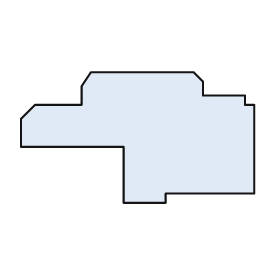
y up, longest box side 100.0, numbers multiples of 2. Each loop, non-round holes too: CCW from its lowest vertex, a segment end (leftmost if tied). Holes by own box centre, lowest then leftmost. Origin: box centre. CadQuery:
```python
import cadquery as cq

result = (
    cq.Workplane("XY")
    .moveTo(-6.0, -28.0)
    .lineTo(12.0, -28.0)
    .lineTo(12.0, -24.0)
    .lineTo(50.0, -24.0)
    .lineTo(50.0, 14.0)
    .lineTo(46.0, 14.0)
    .lineTo(46.0, 18.0)
    .lineTo(28.0, 18.0)
    .lineTo(28.0, 24.0)
    .lineTo(24.0, 28.0)
    .lineTo(-20.0, 28.0)
    .lineTo(-24.0, 22.0)
    .lineTo(-24.0, 14.0)
    .lineTo(-44.0, 14.0)
    .lineTo(-50.0, 8.0)
    .lineTo(-50.0, -4.0)
    .lineTo(-6.0, -4.0)
    .close()
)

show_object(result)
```